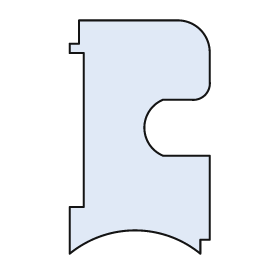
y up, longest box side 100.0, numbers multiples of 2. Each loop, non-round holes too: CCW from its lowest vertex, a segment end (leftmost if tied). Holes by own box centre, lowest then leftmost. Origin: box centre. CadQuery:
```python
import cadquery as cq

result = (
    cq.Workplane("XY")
    .moveTo(-30.0, -50.0)
    .threePointArc((-2.0, -40.0), (26.0, -50.0))
    .lineTo(26.0, -44.0)
    .lineTo(30.0, -44.0)
    .lineTo(30.0, -8.0)
    .lineTo(10.0, -8.0)
    .threePointArc((2.0, 4.0), (10.0, 16.0))
    .lineTo(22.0, 16.0)
    .threePointArc((28.0, 18.0), (30.0, 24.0))
    .lineTo(30.0, 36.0)
    .threePointArc((26.0, 46.0), (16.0, 50.0))
    .lineTo(-26.0, 50.0)
    .lineTo(-26.0, 40.0)
    .lineTo(-30.0, 40.0)
    .lineTo(-30.0, 36.0)
    .lineTo(-24.0, 36.0)
    .lineTo(-24.0, -30.0)
    .lineTo(-30.0, -30.0)
    .close()
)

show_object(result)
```